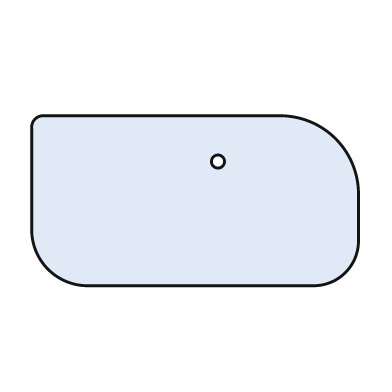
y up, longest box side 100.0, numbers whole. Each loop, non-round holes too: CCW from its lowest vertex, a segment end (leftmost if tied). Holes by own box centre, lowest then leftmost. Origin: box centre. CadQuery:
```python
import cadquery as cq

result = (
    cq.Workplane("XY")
    .moveTo(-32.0, -26.0)
    .lineTo(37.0, -26.0)
    .threePointArc((46.0, -22.0), (50.0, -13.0))
    .lineTo(50.0, 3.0)
    .threePointArc((43.0, 19.0), (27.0, 26.0))
    .lineTo(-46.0, 26.0)
    .threePointArc((-49.0, 25.0), (-50.0, 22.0))
    .lineTo(-50.0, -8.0)
    .threePointArc((-45.0, -21.0), (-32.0, -26.0))
    .close()
    .moveTo(7.0, 12.0)
    .circle(2.0)
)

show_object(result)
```